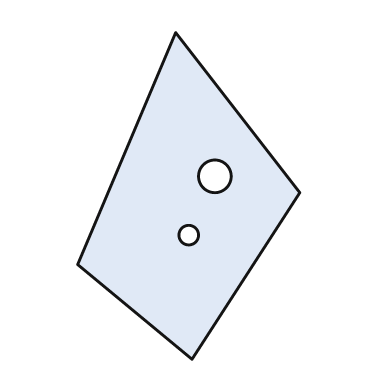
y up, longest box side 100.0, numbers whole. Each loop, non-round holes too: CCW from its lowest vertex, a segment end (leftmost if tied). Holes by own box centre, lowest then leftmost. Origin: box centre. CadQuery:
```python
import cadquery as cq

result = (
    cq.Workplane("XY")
    .moveTo(1.0, -50.0)
    .lineTo(34.0, 1.0)
    .lineTo(-4.0, 50.0)
    .lineTo(-34.0, -21.0)
    .close()
    .moveTo(0.0, -12.0)
    .circle(3.0)
    .moveTo(8.0, 6.0)
    .circle(5.0)
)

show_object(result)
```